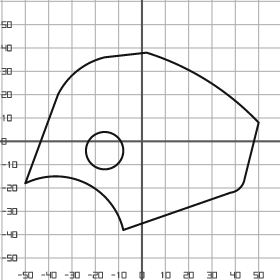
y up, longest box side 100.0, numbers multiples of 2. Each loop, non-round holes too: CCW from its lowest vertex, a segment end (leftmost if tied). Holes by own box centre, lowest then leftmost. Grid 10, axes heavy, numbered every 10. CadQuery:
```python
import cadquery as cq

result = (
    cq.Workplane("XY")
    .moveTo(-8.0, -38.0)
    .lineTo(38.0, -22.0)
    .threePointArc((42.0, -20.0), (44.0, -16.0))
    .lineTo(50.0, 8.0)
    .threePointArc((28.0, 26.0), (2.0, 38.0))
    .lineTo(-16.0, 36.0)
    .threePointArc((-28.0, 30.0), (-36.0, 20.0))
    .lineTo(-50.0, -18.0)
    .threePointArc((-24.0, -18.0), (-8.0, -38.0))
    .close()
    .moveTo(-16.0, -4.0)
    .circle(8.0)
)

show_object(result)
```